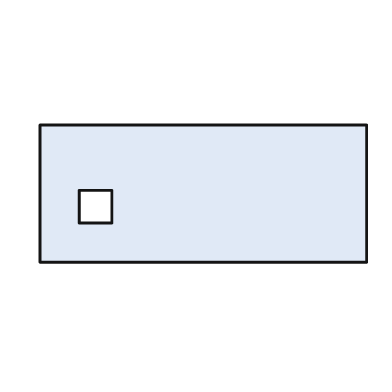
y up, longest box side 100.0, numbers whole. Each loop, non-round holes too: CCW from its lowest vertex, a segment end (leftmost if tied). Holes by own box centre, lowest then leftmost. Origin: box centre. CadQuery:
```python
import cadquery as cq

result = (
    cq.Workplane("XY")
    .moveTo(-50.0, -21.0)
    .lineTo(50.0, -21.0)
    .lineTo(50.0, 21.0)
    .lineTo(-50.0, 21.0)
    .close()
    .moveTo(-38.0, -9.0)
    .lineTo(-28.0, -9.0)
    .lineTo(-28.0, 1.0)
    .lineTo(-38.0, 1.0)
    .close()
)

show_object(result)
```